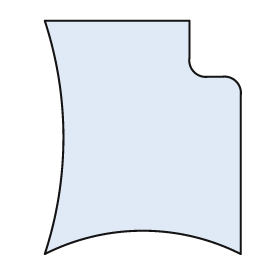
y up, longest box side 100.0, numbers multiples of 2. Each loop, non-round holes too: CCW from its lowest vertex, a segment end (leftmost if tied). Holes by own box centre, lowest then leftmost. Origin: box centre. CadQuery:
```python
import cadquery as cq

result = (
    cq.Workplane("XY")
    .moveTo(-42.0, -50.0)
    .threePointArc((0.0, -40.0), (42.0, -50.0))
    .lineTo(42.0, 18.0)
    .threePointArc((40.0, 24.0), (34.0, 26.0))
    .lineTo(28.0, 26.0)
    .threePointArc((22.0, 28.0), (20.0, 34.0))
    .lineTo(20.0, 50.0)
    .lineTo(-42.0, 50.0)
    .threePointArc((-34.0, 0.0), (-42.0, -50.0))
    .close()
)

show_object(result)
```